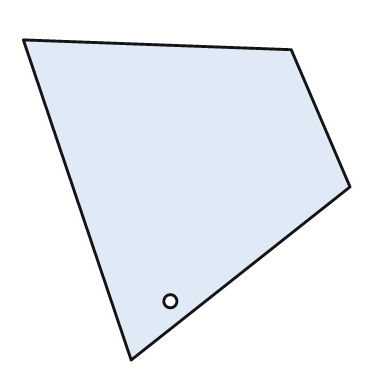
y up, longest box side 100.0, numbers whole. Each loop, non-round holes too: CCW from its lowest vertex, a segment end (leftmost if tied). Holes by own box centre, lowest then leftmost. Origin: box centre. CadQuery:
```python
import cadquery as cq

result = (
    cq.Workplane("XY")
    .moveTo(-17.0, -49.0)
    .lineTo(50.0, 4.0)
    .lineTo(32.0, 46.0)
    .lineTo(-50.0, 49.0)
    .close()
    .moveTo(-5.0, -31.0)
    .circle(2.0)
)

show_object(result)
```